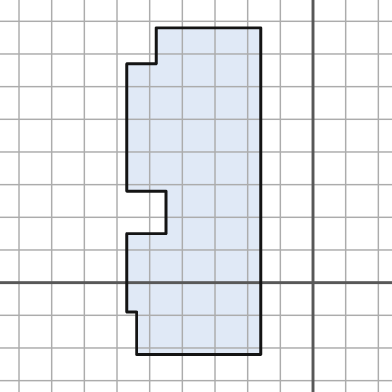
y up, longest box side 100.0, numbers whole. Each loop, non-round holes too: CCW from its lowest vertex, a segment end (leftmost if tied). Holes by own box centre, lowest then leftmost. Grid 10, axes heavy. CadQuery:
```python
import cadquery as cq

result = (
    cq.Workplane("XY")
    .moveTo(-54.0, -22.0)
    .lineTo(-16.0, -22.0)
    .lineTo(-16.0, 78.0)
    .lineTo(-48.0, 78.0)
    .lineTo(-48.0, 67.0)
    .lineTo(-57.0, 67.0)
    .lineTo(-57.0, 28.0)
    .lineTo(-45.0, 28.0)
    .lineTo(-45.0, 15.0)
    .lineTo(-57.0, 15.0)
    .lineTo(-57.0, -9.0)
    .lineTo(-54.0, -9.0)
    .close()
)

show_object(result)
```